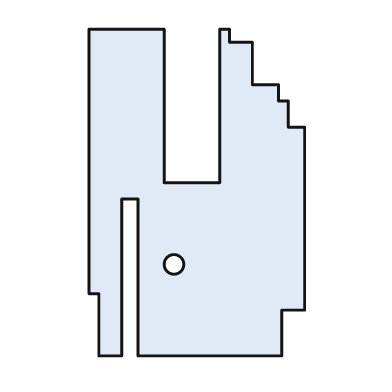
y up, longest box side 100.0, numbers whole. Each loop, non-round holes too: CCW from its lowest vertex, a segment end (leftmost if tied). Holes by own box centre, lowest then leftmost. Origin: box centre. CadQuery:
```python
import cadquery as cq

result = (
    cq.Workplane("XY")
    .moveTo(-30.0, -50.0)
    .lineTo(-23.0, -50.0)
    .lineTo(-23.0, -2.0)
    .lineTo(-18.0, -2.0)
    .lineTo(-18.0, -50.0)
    .lineTo(26.0, -50.0)
    .lineTo(26.0, -36.0)
    .lineTo(33.0, -36.0)
    .lineTo(33.0, 20.0)
    .lineTo(28.0, 20.0)
    .lineTo(28.0, 28.0)
    .lineTo(25.0, 28.0)
    .lineTo(25.0, 33.0)
    .lineTo(17.0, 33.0)
    .lineTo(17.0, 46.0)
    .lineTo(10.0, 46.0)
    .lineTo(10.0, 50.0)
    .lineTo(7.0, 50.0)
    .lineTo(7.0, 3.0)
    .lineTo(-10.0, 3.0)
    .lineTo(-10.0, 50.0)
    .lineTo(-33.0, 50.0)
    .lineTo(-33.0, -31.0)
    .lineTo(-30.0, -31.0)
    .close()
    .moveTo(-7.0, -22.0)
    .circle(3.0)
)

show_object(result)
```